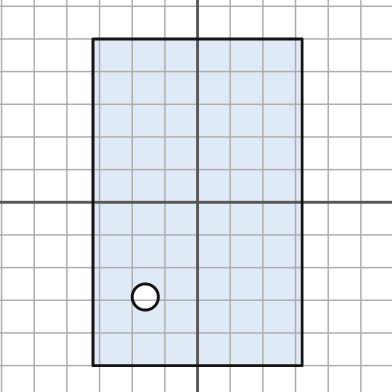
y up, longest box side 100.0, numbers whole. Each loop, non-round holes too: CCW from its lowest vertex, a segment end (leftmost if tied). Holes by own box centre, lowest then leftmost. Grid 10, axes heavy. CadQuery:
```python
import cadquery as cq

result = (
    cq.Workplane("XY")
    .moveTo(-32.0, -50.0)
    .lineTo(32.0, -50.0)
    .lineTo(32.0, 50.0)
    .lineTo(-32.0, 50.0)
    .close()
    .moveTo(-16.0, -29.0)
    .circle(4.0)
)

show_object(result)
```